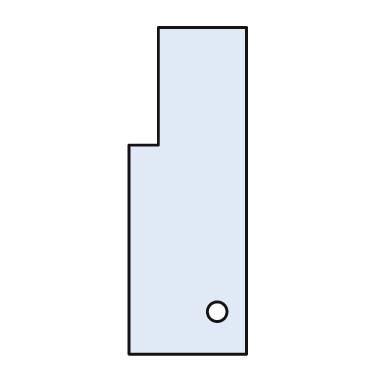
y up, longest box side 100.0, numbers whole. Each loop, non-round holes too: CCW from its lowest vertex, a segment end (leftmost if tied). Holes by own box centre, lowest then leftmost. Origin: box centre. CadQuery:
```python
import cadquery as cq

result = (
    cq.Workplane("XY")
    .moveTo(-18.0, -50.0)
    .lineTo(18.0, -50.0)
    .lineTo(18.0, 50.0)
    .lineTo(-9.0, 50.0)
    .lineTo(-9.0, 14.0)
    .lineTo(-18.0, 14.0)
    .close()
    .moveTo(9.0, -37.0)
    .circle(3.0)
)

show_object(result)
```